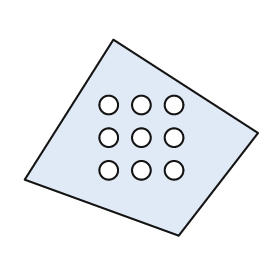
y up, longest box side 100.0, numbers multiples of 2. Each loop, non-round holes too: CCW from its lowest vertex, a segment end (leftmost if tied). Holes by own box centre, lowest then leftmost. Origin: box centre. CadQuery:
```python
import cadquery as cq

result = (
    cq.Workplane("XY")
    .moveTo(16.0, -42.0)
    .lineTo(50.0, 2.0)
    .lineTo(-12.0, 42.0)
    .lineTo(-50.0, -18.0)
    .close()
    .moveTo(-14.0, -14.0)
    .circle(4.0)
    .moveTo(0.0, -14.0)
    .circle(4.0)
    .moveTo(14.0, -14.0)
    .circle(4.0)
    .moveTo(-14.0, 0.0)
    .circle(4.0)
    .moveTo(0.0, 0.0)
    .circle(4.0)
    .moveTo(14.0, 0.0)
    .circle(4.0)
    .moveTo(-14.0, 14.0)
    .circle(4.0)
    .moveTo(0.0, 14.0)
    .circle(4.0)
    .moveTo(14.0, 14.0)
    .circle(4.0)
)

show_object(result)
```